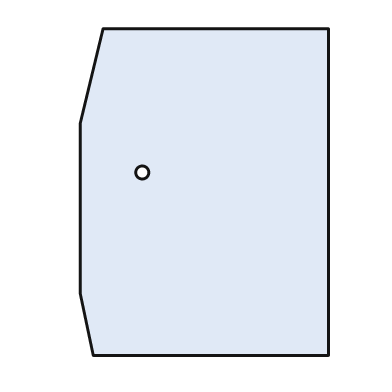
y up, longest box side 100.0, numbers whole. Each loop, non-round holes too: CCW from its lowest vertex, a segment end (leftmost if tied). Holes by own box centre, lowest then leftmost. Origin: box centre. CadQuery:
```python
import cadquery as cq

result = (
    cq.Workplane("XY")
    .moveTo(-34.0, -50.0)
    .lineTo(38.0, -50.0)
    .lineTo(38.0, 50.0)
    .lineTo(-31.0, 50.0)
    .lineTo(-38.0, 21.0)
    .lineTo(-38.0, -31.0)
    .close()
    .moveTo(-19.0, 6.0)
    .circle(2.0)
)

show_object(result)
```